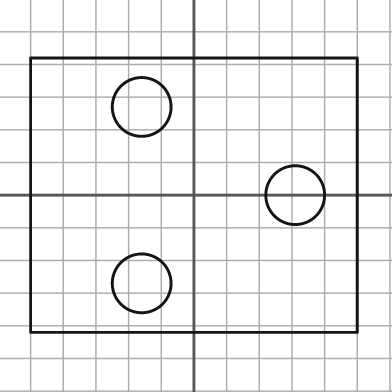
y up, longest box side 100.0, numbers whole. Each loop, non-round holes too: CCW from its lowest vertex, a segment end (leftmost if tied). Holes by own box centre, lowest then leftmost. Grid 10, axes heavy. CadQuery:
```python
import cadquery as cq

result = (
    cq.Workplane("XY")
    .moveTo(-50.0, -42.0)
    .lineTo(50.0, -42.0)
    .lineTo(50.0, 42.0)
    .lineTo(-50.0, 42.0)
    .close()
    .moveTo(-16.0, -27.0)
    .circle(9.0)
    .moveTo(31.0, 0.0)
    .circle(9.0)
    .moveTo(-16.0, 27.0)
    .circle(9.0)
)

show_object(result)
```